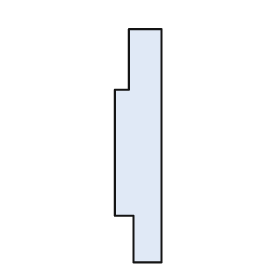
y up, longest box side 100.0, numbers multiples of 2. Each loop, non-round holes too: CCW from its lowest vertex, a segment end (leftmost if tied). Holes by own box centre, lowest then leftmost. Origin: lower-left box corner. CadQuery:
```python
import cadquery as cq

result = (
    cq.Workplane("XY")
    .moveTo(8.0, 0.0)
    .lineTo(20.0, 0.0)
    .lineTo(20.0, 100.0)
    .lineTo(6.0, 100.0)
    .lineTo(6.0, 74.0)
    .lineTo(0.0, 74.0)
    .lineTo(0.0, 20.0)
    .lineTo(8.0, 20.0)
    .close()
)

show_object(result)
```